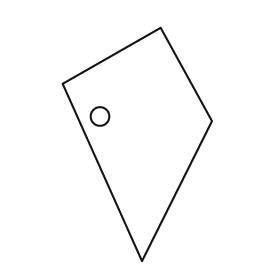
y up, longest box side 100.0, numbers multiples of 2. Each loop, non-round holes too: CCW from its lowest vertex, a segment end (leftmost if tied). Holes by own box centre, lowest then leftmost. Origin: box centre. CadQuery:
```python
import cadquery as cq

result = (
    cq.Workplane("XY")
    .moveTo(2.0, -50.0)
    .lineTo(32.0, 10.0)
    .lineTo(10.0, 50.0)
    .lineTo(-32.0, 26.0)
    .close()
    .moveTo(-16.0, 12.0)
    .circle(4.0)
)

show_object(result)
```